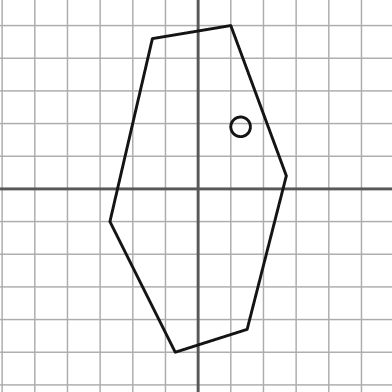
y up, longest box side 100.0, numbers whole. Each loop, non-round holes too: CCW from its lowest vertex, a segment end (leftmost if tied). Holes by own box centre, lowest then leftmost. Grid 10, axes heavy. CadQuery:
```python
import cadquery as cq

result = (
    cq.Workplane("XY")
    .moveTo(-7.0, -50.0)
    .lineTo(15.0, -43.0)
    .lineTo(27.0, 4.0)
    .lineTo(10.0, 50.0)
    .lineTo(-14.0, 46.0)
    .lineTo(-27.0, -10.0)
    .close()
    .moveTo(13.0, 19.0)
    .circle(3.0)
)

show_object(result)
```